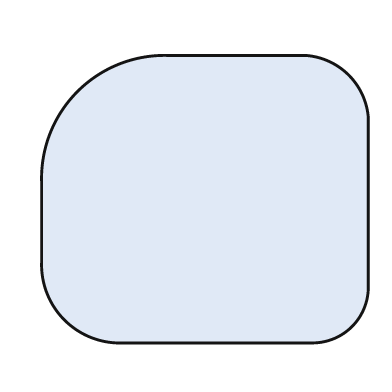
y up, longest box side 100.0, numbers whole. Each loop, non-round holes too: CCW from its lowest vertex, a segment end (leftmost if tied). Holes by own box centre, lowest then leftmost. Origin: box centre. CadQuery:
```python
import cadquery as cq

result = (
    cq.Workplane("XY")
    .moveTo(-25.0, -44.0)
    .lineTo(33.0, -44.0)
    .threePointArc((45.0, -39.0), (50.0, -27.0))
    .lineTo(50.0, 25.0)
    .threePointArc((44.0, 38.0), (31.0, 44.0))
    .lineTo(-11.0, 44.0)
    .threePointArc((-39.0, 33.0), (-50.0, 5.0))
    .lineTo(-50.0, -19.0)
    .threePointArc((-43.0, -37.0), (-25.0, -44.0))
    .close()
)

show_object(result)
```